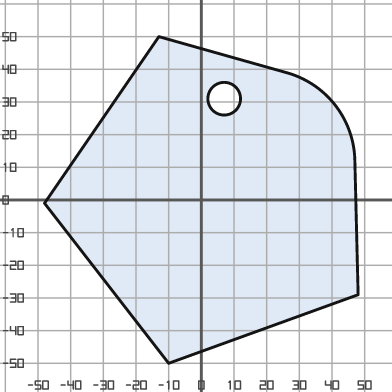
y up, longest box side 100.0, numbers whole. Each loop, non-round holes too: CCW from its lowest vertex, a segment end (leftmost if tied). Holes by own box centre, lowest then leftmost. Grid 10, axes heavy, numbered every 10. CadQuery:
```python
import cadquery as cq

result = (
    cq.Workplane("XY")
    .moveTo(-10.0, -50.0)
    .lineTo(48.0, -29.0)
    .lineTo(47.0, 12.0)
    .threePointArc((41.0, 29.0), (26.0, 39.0))
    .lineTo(-13.0, 50.0)
    .lineTo(-48.0, -1.0)
    .close()
    .moveTo(7.0, 31.0)
    .circle(5.0)
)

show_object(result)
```